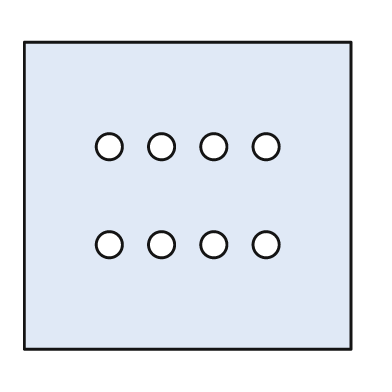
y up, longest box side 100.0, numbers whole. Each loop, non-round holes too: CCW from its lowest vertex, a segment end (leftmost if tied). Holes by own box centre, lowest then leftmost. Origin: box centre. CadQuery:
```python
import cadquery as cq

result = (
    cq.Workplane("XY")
    .moveTo(-50.0, -47.0)
    .lineTo(50.0, -47.0)
    .lineTo(50.0, 47.0)
    .lineTo(-50.0, 47.0)
    .close()
    .moveTo(-24.0, -15.0)
    .circle(4.0)
    .moveTo(-8.0, -15.0)
    .circle(4.0)
    .moveTo(8.0, -15.0)
    .circle(4.0)
    .moveTo(24.0, -15.0)
    .circle(4.0)
    .moveTo(-24.0, 15.0)
    .circle(4.0)
    .moveTo(-8.0, 15.0)
    .circle(4.0)
    .moveTo(8.0, 15.0)
    .circle(4.0)
    .moveTo(24.0, 15.0)
    .circle(4.0)
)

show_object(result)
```